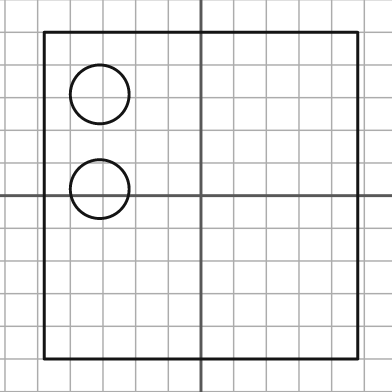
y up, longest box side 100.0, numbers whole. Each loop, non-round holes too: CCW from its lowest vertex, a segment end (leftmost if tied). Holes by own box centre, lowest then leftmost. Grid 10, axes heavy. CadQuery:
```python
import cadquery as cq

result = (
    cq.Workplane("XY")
    .moveTo(-48.0, -50.0)
    .lineTo(48.0, -50.0)
    .lineTo(48.0, 50.0)
    .lineTo(-48.0, 50.0)
    .close()
    .moveTo(-31.0, 2.0)
    .circle(9.0)
    .moveTo(-31.0, 31.0)
    .circle(9.0)
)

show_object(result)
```